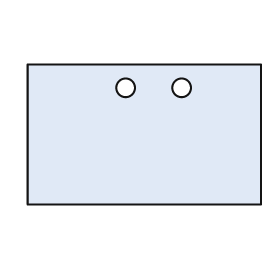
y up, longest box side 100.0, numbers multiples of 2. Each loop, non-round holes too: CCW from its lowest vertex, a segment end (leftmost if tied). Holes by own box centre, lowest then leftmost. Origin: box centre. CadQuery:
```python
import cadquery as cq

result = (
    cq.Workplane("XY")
    .moveTo(-50.0, -30.0)
    .lineTo(50.0, -30.0)
    .lineTo(50.0, 30.0)
    .lineTo(-50.0, 30.0)
    .close()
    .moveTo(-8.0, 20.0)
    .circle(4.0)
    .moveTo(16.0, 20.0)
    .circle(4.0)
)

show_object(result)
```